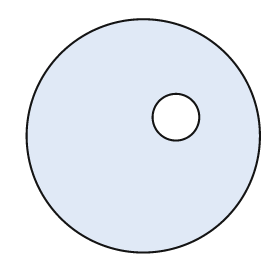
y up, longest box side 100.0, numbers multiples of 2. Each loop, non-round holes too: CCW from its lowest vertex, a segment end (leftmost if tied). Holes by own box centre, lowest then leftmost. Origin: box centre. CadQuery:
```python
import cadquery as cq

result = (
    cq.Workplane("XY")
    .moveTo(0.0, 0.0)
    .circle(50.0)
    .moveTo(14.0, 8.0)
    .circle(10.0)
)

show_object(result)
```